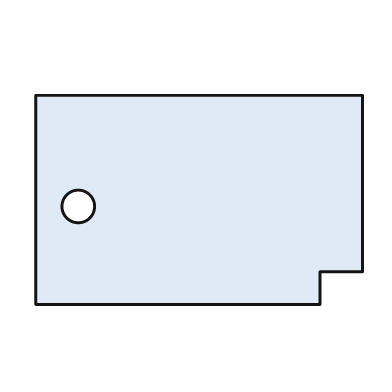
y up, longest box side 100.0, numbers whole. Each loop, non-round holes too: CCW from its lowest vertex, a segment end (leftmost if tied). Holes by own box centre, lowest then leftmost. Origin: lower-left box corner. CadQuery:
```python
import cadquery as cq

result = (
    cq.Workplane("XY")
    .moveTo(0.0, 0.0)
    .lineTo(87.0, 0.0)
    .lineTo(87.0, 10.0)
    .lineTo(100.0, 10.0)
    .lineTo(100.0, 64.0)
    .lineTo(0.0, 64.0)
    .close()
    .moveTo(13.0, 30.0)
    .circle(5.0)
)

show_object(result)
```